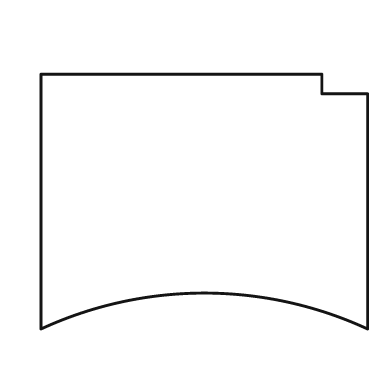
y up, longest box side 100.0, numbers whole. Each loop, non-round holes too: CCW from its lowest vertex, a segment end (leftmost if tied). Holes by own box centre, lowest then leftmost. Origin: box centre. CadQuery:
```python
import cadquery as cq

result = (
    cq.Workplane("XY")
    .moveTo(-50.0, -39.0)
    .threePointArc((0.0, -28.0), (50.0, -39.0))
    .lineTo(50.0, 33.0)
    .lineTo(36.0, 33.0)
    .lineTo(36.0, 39.0)
    .lineTo(-50.0, 39.0)
    .close()
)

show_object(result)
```